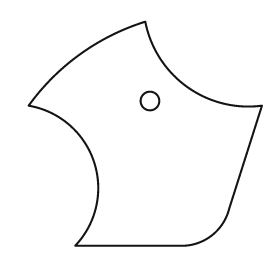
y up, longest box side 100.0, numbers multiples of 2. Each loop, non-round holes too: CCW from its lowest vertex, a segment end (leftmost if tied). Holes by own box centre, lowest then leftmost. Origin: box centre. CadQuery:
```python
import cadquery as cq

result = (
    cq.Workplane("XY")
    .moveTo(-30.0, -48.0)
    .lineTo(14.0, -48.0)
    .threePointArc((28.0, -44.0), (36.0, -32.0))
    .lineTo(50.0, 12.0)
    .threePointArc((18.0, 20.0), (0.0, 48.0))
    .threePointArc((-28.0, 34.0), (-50.0, 12.0))
    .threePointArc((-22.0, -12.0), (-30.0, -48.0))
    .close()
    .moveTo(2.0, 14.0)
    .circle(4.0)
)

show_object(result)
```